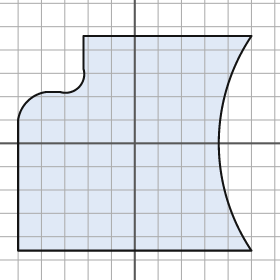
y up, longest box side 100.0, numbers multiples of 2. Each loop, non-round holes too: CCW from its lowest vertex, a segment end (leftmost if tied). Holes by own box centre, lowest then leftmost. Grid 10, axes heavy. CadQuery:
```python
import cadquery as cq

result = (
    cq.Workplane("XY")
    .moveTo(-50.0, -46.0)
    .lineTo(50.0, -46.0)
    .threePointArc((36.0, 0.0), (50.0, 46.0))
    .lineTo(-22.0, 46.0)
    .lineTo(-22.0, 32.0)
    .threePointArc((-24.0, 24.0), (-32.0, 22.0))
    .lineTo(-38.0, 22.0)
    .threePointArc((-46.0, 18.0), (-50.0, 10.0))
    .close()
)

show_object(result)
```